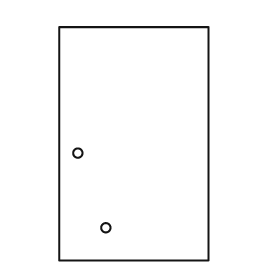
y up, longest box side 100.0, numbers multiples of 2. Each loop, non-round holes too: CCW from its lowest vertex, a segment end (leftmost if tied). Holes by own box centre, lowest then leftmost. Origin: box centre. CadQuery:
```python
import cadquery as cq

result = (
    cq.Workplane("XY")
    .moveTo(-32.0, -50.0)
    .lineTo(32.0, -50.0)
    .lineTo(32.0, 50.0)
    .lineTo(-32.0, 50.0)
    .close()
    .moveTo(-12.0, -36.0)
    .circle(2.0)
    .moveTo(-24.0, -4.0)
    .circle(2.0)
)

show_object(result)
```